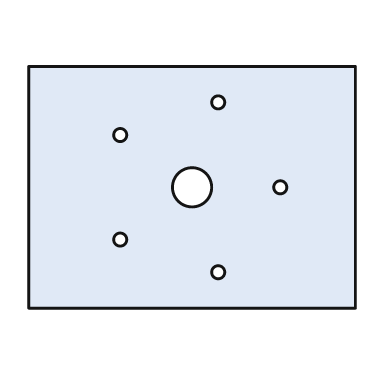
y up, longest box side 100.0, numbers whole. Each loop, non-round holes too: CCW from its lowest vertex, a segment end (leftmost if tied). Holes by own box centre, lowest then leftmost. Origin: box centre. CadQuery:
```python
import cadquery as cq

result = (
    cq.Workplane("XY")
    .moveTo(-50.0, -37.0)
    .lineTo(50.0, -37.0)
    .lineTo(50.0, 37.0)
    .lineTo(-50.0, 37.0)
    .close()
    .moveTo(8.0, -26.0)
    .circle(2.0)
    .moveTo(-22.0, -16.0)
    .circle(2.0)
    .moveTo(0.0, 0.0)
    .circle(6.0)
    .moveTo(27.0, 0.0)
    .circle(2.0)
    .moveTo(-22.0, 16.0)
    .circle(2.0)
    .moveTo(8.0, 26.0)
    .circle(2.0)
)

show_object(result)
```